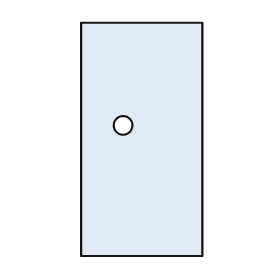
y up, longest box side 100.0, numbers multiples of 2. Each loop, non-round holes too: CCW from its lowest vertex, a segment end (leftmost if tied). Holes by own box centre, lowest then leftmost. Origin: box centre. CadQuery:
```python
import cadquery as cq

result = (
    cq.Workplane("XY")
    .moveTo(-26.0, -50.0)
    .lineTo(26.0, -50.0)
    .lineTo(26.0, 50.0)
    .lineTo(-26.0, 50.0)
    .close()
    .moveTo(-8.0, 6.0)
    .circle(4.0)
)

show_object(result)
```